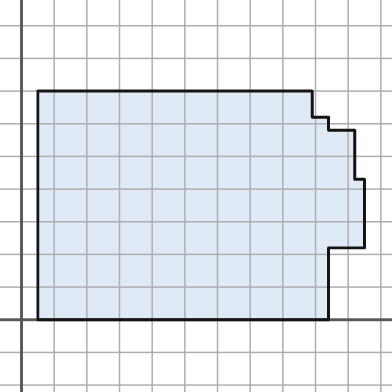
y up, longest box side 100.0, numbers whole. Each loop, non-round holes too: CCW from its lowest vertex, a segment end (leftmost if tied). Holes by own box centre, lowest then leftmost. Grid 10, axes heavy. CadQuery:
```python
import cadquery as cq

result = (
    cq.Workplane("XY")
    .moveTo(5.0, 0.0)
    .lineTo(94.0, 0.0)
    .lineTo(94.0, 22.0)
    .lineTo(105.0, 22.0)
    .lineTo(105.0, 43.0)
    .lineTo(102.0, 43.0)
    .lineTo(102.0, 58.0)
    .lineTo(94.0, 58.0)
    .lineTo(94.0, 62.0)
    .lineTo(89.0, 62.0)
    .lineTo(89.0, 70.0)
    .lineTo(5.0, 70.0)
    .close()
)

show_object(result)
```